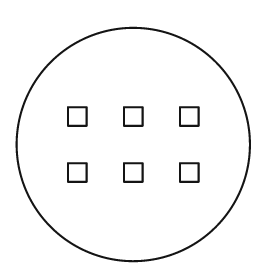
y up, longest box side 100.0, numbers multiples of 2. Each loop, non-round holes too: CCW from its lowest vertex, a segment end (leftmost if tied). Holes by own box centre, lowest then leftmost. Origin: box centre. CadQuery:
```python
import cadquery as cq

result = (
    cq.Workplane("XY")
    .moveTo(0.0, 0.0)
    .circle(50.0)
    .moveTo(-28.0, -16.0)
    .lineTo(-20.0, -16.0)
    .lineTo(-20.0, -8.0)
    .lineTo(-28.0, -8.0)
    .close()
    .moveTo(-4.0, -16.0)
    .lineTo(4.0, -16.0)
    .lineTo(4.0, -8.0)
    .lineTo(-4.0, -8.0)
    .close()
    .moveTo(20.0, -16.0)
    .lineTo(28.0, -16.0)
    .lineTo(28.0, -8.0)
    .lineTo(20.0, -8.0)
    .close()
    .moveTo(-28.0, 8.0)
    .lineTo(-20.0, 8.0)
    .lineTo(-20.0, 16.0)
    .lineTo(-28.0, 16.0)
    .close()
    .moveTo(-4.0, 8.0)
    .lineTo(4.0, 8.0)
    .lineTo(4.0, 16.0)
    .lineTo(-4.0, 16.0)
    .close()
    .moveTo(20.0, 8.0)
    .lineTo(28.0, 8.0)
    .lineTo(28.0, 16.0)
    .lineTo(20.0, 16.0)
    .close()
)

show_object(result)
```